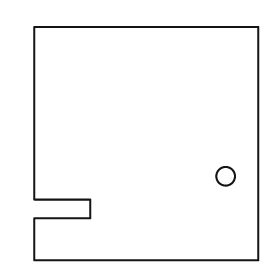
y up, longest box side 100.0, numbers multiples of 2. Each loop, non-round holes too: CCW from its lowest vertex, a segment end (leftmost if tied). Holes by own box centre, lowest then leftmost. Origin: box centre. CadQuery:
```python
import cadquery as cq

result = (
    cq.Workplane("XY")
    .moveTo(-48.0, -50.0)
    .lineTo(48.0, -50.0)
    .lineTo(48.0, 50.0)
    .lineTo(-48.0, 50.0)
    .lineTo(-48.0, -24.0)
    .lineTo(-24.0, -24.0)
    .lineTo(-24.0, -32.0)
    .lineTo(-48.0, -32.0)
    .close()
    .moveTo(34.0, -14.0)
    .circle(4.0)
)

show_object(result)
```